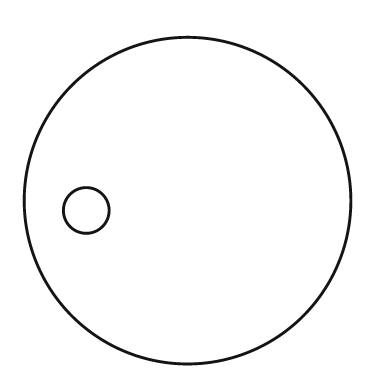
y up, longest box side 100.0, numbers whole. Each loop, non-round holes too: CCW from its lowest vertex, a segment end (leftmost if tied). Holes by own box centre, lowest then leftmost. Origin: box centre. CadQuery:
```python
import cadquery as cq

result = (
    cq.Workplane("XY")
    .moveTo(0.0, 0.0)
    .circle(50.0)
    .moveTo(-31.0, -3.0)
    .circle(7.0)
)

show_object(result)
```